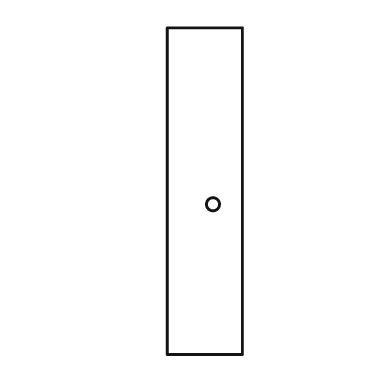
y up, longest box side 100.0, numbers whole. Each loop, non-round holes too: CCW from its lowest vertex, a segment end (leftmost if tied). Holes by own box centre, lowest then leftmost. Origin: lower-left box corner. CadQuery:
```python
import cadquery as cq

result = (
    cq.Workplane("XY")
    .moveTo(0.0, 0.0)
    .lineTo(23.0, 0.0)
    .lineTo(23.0, 100.0)
    .lineTo(0.0, 100.0)
    .close()
    .moveTo(14.0, 46.0)
    .circle(2.0)
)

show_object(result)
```